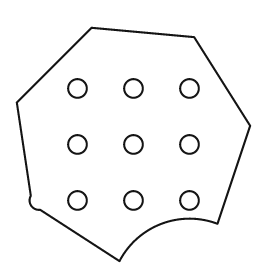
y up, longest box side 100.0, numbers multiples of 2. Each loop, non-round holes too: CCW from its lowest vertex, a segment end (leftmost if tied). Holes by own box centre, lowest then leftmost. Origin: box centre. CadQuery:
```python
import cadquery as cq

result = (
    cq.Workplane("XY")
    .moveTo(-6.0, -50.0)
    .threePointArc((12.0, -34.0), (36.0, -34.0))
    .lineTo(50.0, 8.0)
    .lineTo(26.0, 46.0)
    .lineTo(-18.0, 50.0)
    .lineTo(-50.0, 18.0)
    .lineTo(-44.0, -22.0)
    .threePointArc((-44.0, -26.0), (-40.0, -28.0))
    .close()
    .moveTo(-24.0, -24.0)
    .circle(4.0)
    .moveTo(0.0, -24.0)
    .circle(4.0)
    .moveTo(24.0, -24.0)
    .circle(4.0)
    .moveTo(-24.0, 0.0)
    .circle(4.0)
    .moveTo(0.0, 0.0)
    .circle(4.0)
    .moveTo(24.0, 0.0)
    .circle(4.0)
    .moveTo(-24.0, 24.0)
    .circle(4.0)
    .moveTo(0.0, 24.0)
    .circle(4.0)
    .moveTo(24.0, 24.0)
    .circle(4.0)
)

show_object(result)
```